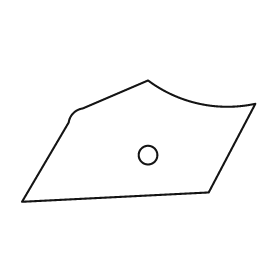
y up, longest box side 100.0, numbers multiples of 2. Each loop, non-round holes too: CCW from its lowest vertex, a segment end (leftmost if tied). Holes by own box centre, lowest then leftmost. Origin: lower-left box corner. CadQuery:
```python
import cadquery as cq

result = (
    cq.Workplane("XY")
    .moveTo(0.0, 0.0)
    .lineTo(80.0, 4.0)
    .lineTo(100.0, 42.0)
    .threePointArc((76.0, 42.0), (54.0, 52.0))
    .lineTo(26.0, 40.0)
    .threePointArc((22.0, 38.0), (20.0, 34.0))
    .close()
    .moveTo(54.0, 20.0)
    .circle(4.0)
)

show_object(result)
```